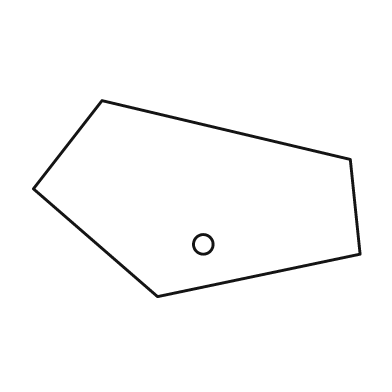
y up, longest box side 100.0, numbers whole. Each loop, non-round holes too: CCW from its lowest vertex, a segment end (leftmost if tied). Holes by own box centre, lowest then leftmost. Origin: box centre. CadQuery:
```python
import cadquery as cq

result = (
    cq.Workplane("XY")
    .moveTo(-12.0, -30.0)
    .lineTo(50.0, -17.0)
    .lineTo(47.0, 12.0)
    .lineTo(-29.0, 30.0)
    .lineTo(-50.0, 3.0)
    .close()
    .moveTo(2.0, -14.0)
    .circle(3.0)
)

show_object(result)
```